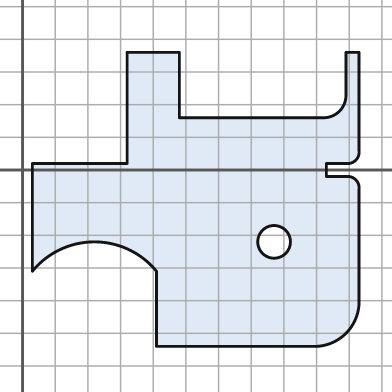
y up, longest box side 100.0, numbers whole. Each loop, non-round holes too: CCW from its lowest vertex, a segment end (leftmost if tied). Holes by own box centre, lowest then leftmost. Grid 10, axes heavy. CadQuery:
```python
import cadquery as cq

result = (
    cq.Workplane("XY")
    .moveTo(41.0, -54.0)
    .lineTo(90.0, -54.0)
    .threePointArc((99.0, -50.0), (103.0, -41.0))
    .lineTo(103.0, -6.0)
    .threePointArc((102.0, -3.0), (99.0, -2.0))
    .lineTo(93.0, -2.0)
    .lineTo(93.0, 2.0)
    .lineTo(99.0, 2.0)
    .threePointArc((102.0, 3.0), (103.0, 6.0))
    .lineTo(103.0, 36.0)
    .lineTo(99.0, 36.0)
    .lineTo(99.0, 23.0)
    .threePointArc((97.0, 18.0), (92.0, 16.0))
    .lineTo(48.0, 16.0)
    .lineTo(48.0, 36.0)
    .lineTo(32.0, 36.0)
    .lineTo(32.0, 2.0)
    .lineTo(3.0, 2.0)
    .lineTo(3.0, -31.0)
    .threePointArc((22.0, -22.0), (41.0, -31.0))
    .close()
    .moveTo(77.0, -22.0)
    .circle(5.0)
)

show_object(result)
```